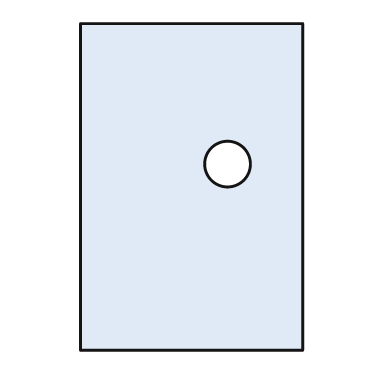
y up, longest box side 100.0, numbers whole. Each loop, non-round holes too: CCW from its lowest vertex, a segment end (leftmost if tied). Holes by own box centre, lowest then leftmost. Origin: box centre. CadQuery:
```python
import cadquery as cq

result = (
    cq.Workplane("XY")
    .moveTo(-34.0, -50.0)
    .lineTo(34.0, -50.0)
    .lineTo(34.0, 50.0)
    .lineTo(-34.0, 50.0)
    .close()
    .moveTo(11.0, 7.0)
    .circle(7.0)
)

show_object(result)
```